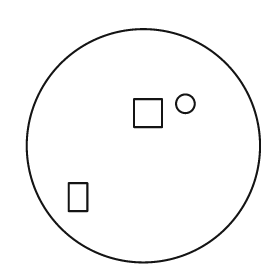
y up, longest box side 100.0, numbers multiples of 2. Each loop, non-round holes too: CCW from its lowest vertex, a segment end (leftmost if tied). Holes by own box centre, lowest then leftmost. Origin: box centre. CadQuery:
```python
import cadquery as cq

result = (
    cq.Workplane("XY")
    .moveTo(0.0, 0.0)
    .circle(50.0)
    .moveTo(-32.0, -28.0)
    .lineTo(-24.0, -28.0)
    .lineTo(-24.0, -16.0)
    .lineTo(-32.0, -16.0)
    .close()
    .moveTo(-4.0, 8.0)
    .lineTo(8.0, 8.0)
    .lineTo(8.0, 20.0)
    .lineTo(-4.0, 20.0)
    .close()
    .moveTo(18.0, 18.0)
    .circle(4.0)
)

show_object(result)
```